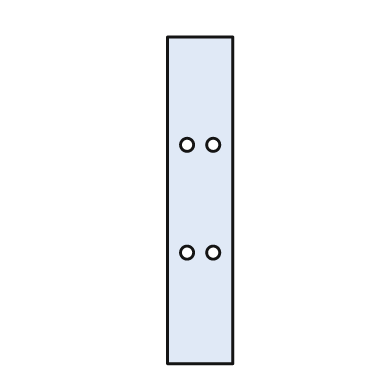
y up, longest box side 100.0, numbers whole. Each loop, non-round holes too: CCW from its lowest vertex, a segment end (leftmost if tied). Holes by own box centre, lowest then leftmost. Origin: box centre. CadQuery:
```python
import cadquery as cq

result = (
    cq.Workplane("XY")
    .moveTo(-10.0, -50.0)
    .lineTo(10.0, -50.0)
    .lineTo(10.0, 50.0)
    .lineTo(-10.0, 50.0)
    .close()
    .moveTo(-4.0, -16.0)
    .circle(2.0)
    .moveTo(4.0, -16.0)
    .circle(2.0)
    .moveTo(-4.0, 17.0)
    .circle(2.0)
    .moveTo(4.0, 17.0)
    .circle(2.0)
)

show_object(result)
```